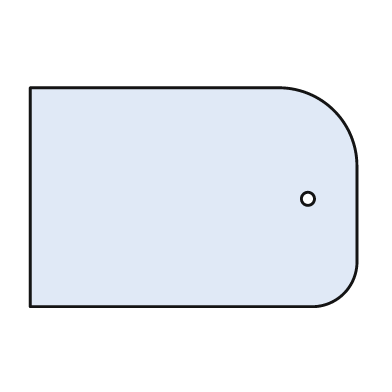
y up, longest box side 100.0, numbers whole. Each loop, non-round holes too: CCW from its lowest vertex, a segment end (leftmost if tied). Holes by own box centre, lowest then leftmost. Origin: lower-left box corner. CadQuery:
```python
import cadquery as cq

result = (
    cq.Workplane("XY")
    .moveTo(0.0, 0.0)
    .lineTo(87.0, 0.0)
    .threePointArc((96.0, 4.0), (100.0, 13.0))
    .lineTo(100.0, 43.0)
    .threePointArc((93.0, 60.0), (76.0, 67.0))
    .lineTo(0.0, 67.0)
    .close()
    .moveTo(85.0, 33.0)
    .circle(2.0)
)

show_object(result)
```